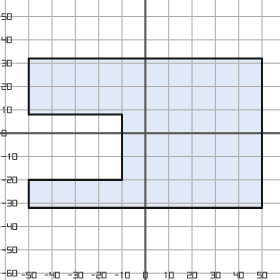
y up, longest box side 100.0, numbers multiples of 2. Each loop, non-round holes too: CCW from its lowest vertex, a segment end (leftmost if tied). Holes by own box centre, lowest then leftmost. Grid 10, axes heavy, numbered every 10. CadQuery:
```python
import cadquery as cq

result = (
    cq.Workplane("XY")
    .moveTo(-50.0, -32.0)
    .lineTo(50.0, -32.0)
    .lineTo(50.0, 32.0)
    .lineTo(-50.0, 32.0)
    .lineTo(-50.0, 8.0)
    .lineTo(-10.0, 8.0)
    .lineTo(-10.0, -20.0)
    .lineTo(-50.0, -20.0)
    .close()
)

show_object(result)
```